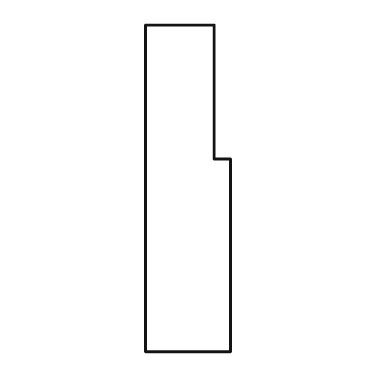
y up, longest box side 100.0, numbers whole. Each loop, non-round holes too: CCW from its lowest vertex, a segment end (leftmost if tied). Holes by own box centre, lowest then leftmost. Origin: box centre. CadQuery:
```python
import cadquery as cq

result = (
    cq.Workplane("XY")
    .moveTo(-13.0, -50.0)
    .lineTo(13.0, -50.0)
    .lineTo(13.0, 9.0)
    .lineTo(8.0, 9.0)
    .lineTo(8.0, 50.0)
    .lineTo(-13.0, 50.0)
    .close()
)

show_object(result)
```